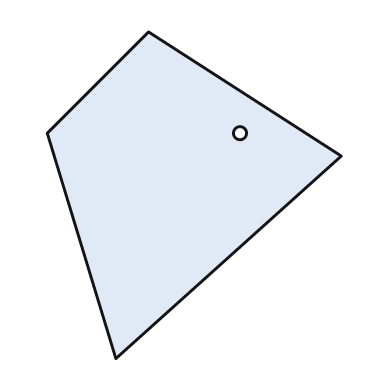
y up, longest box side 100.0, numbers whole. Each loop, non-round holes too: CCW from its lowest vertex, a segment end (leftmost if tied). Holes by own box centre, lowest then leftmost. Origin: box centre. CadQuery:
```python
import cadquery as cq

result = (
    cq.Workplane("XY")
    .moveTo(-24.0, -50.0)
    .lineTo(45.0, 12.0)
    .lineTo(-14.0, 50.0)
    .lineTo(-45.0, 19.0)
    .close()
    .moveTo(14.0, 19.0)
    .circle(2.0)
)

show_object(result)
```